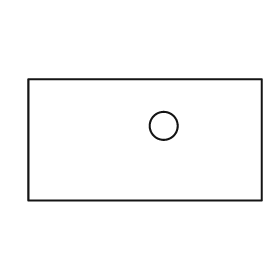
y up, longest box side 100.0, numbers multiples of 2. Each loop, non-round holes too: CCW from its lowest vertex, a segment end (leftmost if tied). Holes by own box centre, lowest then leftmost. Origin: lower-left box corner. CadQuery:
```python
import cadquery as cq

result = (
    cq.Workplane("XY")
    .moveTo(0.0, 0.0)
    .lineTo(100.0, 0.0)
    .lineTo(100.0, 52.0)
    .lineTo(0.0, 52.0)
    .close()
    .moveTo(58.0, 32.0)
    .circle(6.0)
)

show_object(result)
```